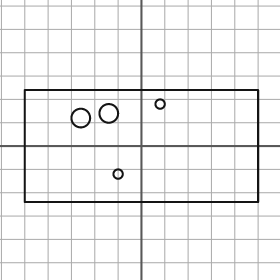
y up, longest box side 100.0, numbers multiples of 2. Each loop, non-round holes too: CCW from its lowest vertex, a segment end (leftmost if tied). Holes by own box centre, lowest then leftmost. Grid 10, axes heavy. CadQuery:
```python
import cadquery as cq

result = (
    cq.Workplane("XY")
    .moveTo(-50.0, -24.0)
    .lineTo(50.0, -24.0)
    .lineTo(50.0, 24.0)
    .lineTo(-50.0, 24.0)
    .close()
    .moveTo(-10.0, -12.0)
    .circle(2.0)
    .moveTo(-26.0, 12.0)
    .circle(4.0)
    .moveTo(-14.0, 14.0)
    .circle(4.0)
    .moveTo(8.0, 18.0)
    .circle(2.0)
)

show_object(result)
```